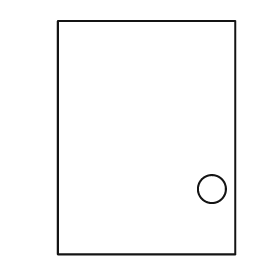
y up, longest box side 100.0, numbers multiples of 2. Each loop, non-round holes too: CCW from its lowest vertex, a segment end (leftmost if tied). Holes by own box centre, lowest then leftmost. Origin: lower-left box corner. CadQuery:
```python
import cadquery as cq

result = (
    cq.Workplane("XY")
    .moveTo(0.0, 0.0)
    .lineTo(76.0, 0.0)
    .lineTo(76.0, 100.0)
    .lineTo(0.0, 100.0)
    .close()
    .moveTo(66.0, 28.0)
    .circle(6.0)
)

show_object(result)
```